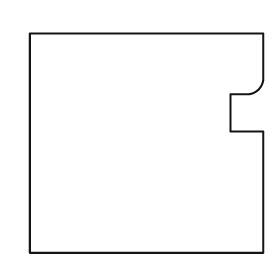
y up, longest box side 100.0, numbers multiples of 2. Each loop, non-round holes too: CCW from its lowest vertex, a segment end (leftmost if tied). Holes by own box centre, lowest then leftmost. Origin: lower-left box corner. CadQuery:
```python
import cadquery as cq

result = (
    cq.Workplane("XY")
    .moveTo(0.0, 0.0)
    .lineTo(100.0, 0.0)
    .lineTo(100.0, 52.0)
    .lineTo(86.0, 52.0)
    .lineTo(86.0, 68.0)
    .lineTo(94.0, 68.0)
    .threePointArc((98.0, 70.0), (100.0, 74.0))
    .lineTo(100.0, 94.0)
    .lineTo(0.0, 94.0)
    .close()
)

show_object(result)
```